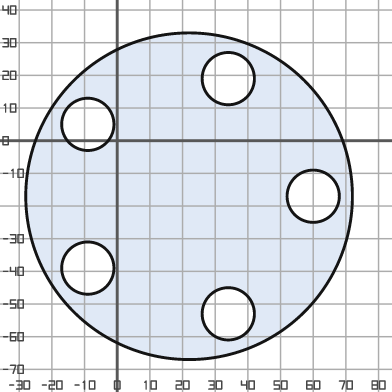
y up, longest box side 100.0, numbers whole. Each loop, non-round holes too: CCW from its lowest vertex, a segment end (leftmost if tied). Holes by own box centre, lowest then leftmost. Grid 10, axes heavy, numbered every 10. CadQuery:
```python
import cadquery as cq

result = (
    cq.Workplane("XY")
    .moveTo(22.0, -17.0)
    .circle(50.0)
    .moveTo(34.0, -53.0)
    .circle(8.0)
    .moveTo(-9.0, -39.0)
    .circle(8.0)
    .moveTo(60.0, -17.0)
    .circle(8.0)
    .moveTo(-9.0, 5.0)
    .circle(8.0)
    .moveTo(34.0, 19.0)
    .circle(8.0)
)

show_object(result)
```